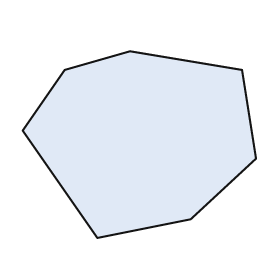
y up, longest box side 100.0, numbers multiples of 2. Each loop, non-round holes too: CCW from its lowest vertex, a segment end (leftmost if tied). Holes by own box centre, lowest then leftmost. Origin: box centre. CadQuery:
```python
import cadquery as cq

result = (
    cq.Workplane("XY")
    .moveTo(-18.0, -40.0)
    .lineTo(22.0, -32.0)
    .lineTo(50.0, -6.0)
    .lineTo(44.0, 32.0)
    .lineTo(-4.0, 40.0)
    .lineTo(-32.0, 32.0)
    .lineTo(-50.0, 6.0)
    .close()
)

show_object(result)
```